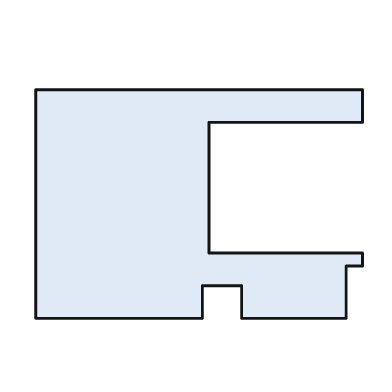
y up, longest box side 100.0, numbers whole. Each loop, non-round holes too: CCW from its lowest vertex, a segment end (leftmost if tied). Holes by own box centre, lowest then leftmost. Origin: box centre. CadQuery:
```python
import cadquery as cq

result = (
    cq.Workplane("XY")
    .moveTo(-50.0, -35.0)
    .lineTo(1.0, -35.0)
    .lineTo(1.0, -25.0)
    .lineTo(13.0, -25.0)
    .lineTo(13.0, -35.0)
    .lineTo(45.0, -35.0)
    .lineTo(45.0, -19.0)
    .lineTo(50.0, -19.0)
    .lineTo(50.0, -15.0)
    .lineTo(3.0, -15.0)
    .lineTo(3.0, 25.0)
    .lineTo(50.0, 25.0)
    .lineTo(50.0, 35.0)
    .lineTo(-50.0, 35.0)
    .close()
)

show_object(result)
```